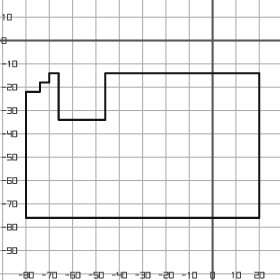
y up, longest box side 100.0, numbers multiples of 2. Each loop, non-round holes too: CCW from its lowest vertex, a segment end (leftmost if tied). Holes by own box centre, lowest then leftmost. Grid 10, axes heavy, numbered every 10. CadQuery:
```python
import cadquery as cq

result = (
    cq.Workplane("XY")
    .moveTo(-80.0, -76.0)
    .lineTo(20.0, -76.0)
    .lineTo(20.0, -14.0)
    .lineTo(-46.0, -14.0)
    .lineTo(-46.0, -34.0)
    .lineTo(-66.0, -34.0)
    .lineTo(-66.0, -14.0)
    .lineTo(-70.0, -14.0)
    .lineTo(-70.0, -18.0)
    .lineTo(-74.0, -18.0)
    .lineTo(-74.0, -22.0)
    .lineTo(-80.0, -22.0)
    .close()
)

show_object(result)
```